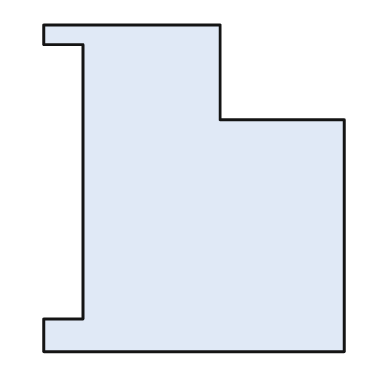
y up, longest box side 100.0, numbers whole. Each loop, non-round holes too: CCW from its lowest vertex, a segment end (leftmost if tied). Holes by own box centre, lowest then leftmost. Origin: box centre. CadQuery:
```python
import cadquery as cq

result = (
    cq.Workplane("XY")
    .moveTo(-46.0, -50.0)
    .lineTo(46.0, -50.0)
    .lineTo(46.0, 21.0)
    .lineTo(8.0, 21.0)
    .lineTo(8.0, 50.0)
    .lineTo(-46.0, 50.0)
    .lineTo(-46.0, 44.0)
    .lineTo(-34.0, 44.0)
    .lineTo(-34.0, -40.0)
    .lineTo(-46.0, -40.0)
    .close()
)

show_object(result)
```